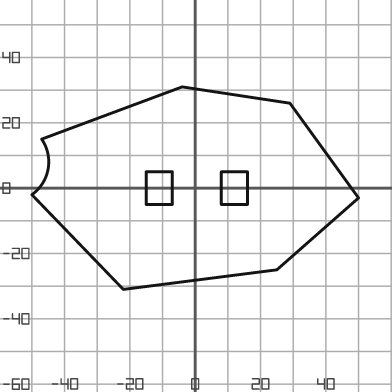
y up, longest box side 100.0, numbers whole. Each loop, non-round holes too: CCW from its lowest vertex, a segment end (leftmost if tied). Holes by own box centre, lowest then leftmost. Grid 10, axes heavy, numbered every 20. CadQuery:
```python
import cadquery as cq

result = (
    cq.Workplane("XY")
    .moveTo(-22.0, -31.0)
    .lineTo(25.0, -25.0)
    .lineTo(50.0, -3.0)
    .lineTo(29.0, 26.0)
    .lineTo(-4.0, 31.0)
    .lineTo(-47.0, 15.0)
    .threePointArc((-45.0, 6.0), (-50.0, -2.0))
    .close()
    .moveTo(-15.0, -5.0)
    .lineTo(-7.0, -5.0)
    .lineTo(-7.0, 5.0)
    .lineTo(-15.0, 5.0)
    .close()
    .moveTo(8.0, -5.0)
    .lineTo(16.0, -5.0)
    .lineTo(16.0, 5.0)
    .lineTo(8.0, 5.0)
    .close()
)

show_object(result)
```